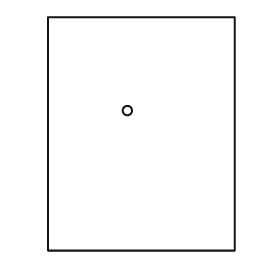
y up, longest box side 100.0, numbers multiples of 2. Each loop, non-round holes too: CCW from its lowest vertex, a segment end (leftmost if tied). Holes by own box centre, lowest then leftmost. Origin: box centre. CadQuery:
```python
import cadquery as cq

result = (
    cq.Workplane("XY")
    .moveTo(-40.0, -50.0)
    .lineTo(40.0, -50.0)
    .lineTo(40.0, 50.0)
    .lineTo(-40.0, 50.0)
    .close()
    .moveTo(-6.0, 10.0)
    .circle(2.0)
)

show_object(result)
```